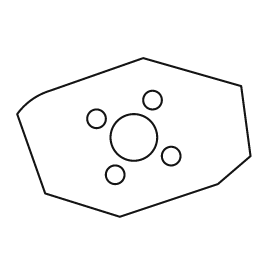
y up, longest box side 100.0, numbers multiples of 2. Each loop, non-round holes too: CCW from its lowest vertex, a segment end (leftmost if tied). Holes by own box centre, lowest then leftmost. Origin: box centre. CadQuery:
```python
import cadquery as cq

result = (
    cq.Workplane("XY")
    .moveTo(-6.0, -34.0)
    .lineTo(36.0, -20.0)
    .lineTo(50.0, -8.0)
    .lineTo(46.0, 22.0)
    .lineTo(4.0, 34.0)
    .lineTo(-36.0, 20.0)
    .threePointArc((-44.0, 16.0), (-50.0, 10.0))
    .lineTo(-38.0, -24.0)
    .close()
    .moveTo(-8.0, -16.0)
    .circle(4.0)
    .moveTo(16.0, -8.0)
    .circle(4.0)
    .moveTo(0.0, 0.0)
    .circle(10.0)
    .moveTo(-16.0, 8.0)
    .circle(4.0)
    .moveTo(8.0, 16.0)
    .circle(4.0)
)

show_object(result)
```